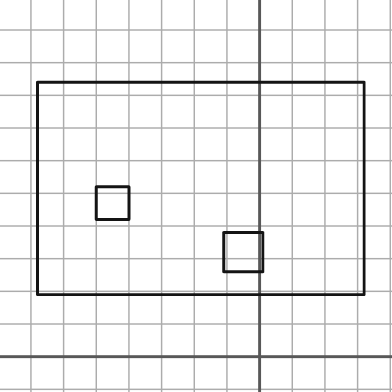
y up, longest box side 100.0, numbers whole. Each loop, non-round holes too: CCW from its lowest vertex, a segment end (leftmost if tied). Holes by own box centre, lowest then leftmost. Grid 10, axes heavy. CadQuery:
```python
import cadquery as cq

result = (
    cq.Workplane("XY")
    .moveTo(-68.0, 19.0)
    .lineTo(32.0, 19.0)
    .lineTo(32.0, 84.0)
    .lineTo(-68.0, 84.0)
    .close()
    .moveTo(-11.0, 26.0)
    .lineTo(1.0, 26.0)
    .lineTo(1.0, 38.0)
    .lineTo(-11.0, 38.0)
    .close()
    .moveTo(-50.0, 42.0)
    .lineTo(-40.0, 42.0)
    .lineTo(-40.0, 52.0)
    .lineTo(-50.0, 52.0)
    .close()
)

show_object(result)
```